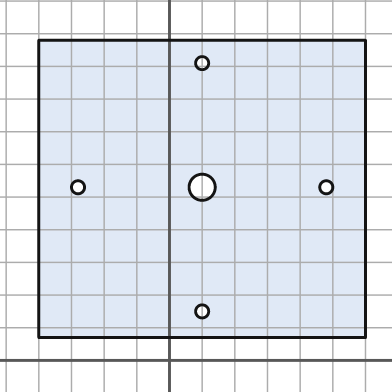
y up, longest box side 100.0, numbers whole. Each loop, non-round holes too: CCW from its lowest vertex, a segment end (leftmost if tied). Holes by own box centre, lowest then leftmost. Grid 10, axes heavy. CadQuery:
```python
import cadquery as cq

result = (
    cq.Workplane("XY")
    .moveTo(-40.0, 7.0)
    .lineTo(60.0, 7.0)
    .lineTo(60.0, 98.0)
    .lineTo(-40.0, 98.0)
    .close()
    .moveTo(10.0, 15.0)
    .circle(2.0)
    .moveTo(-28.0, 53.0)
    .circle(2.0)
    .moveTo(10.0, 53.0)
    .circle(4.0)
    .moveTo(48.0, 53.0)
    .circle(2.0)
    .moveTo(10.0, 91.0)
    .circle(2.0)
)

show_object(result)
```